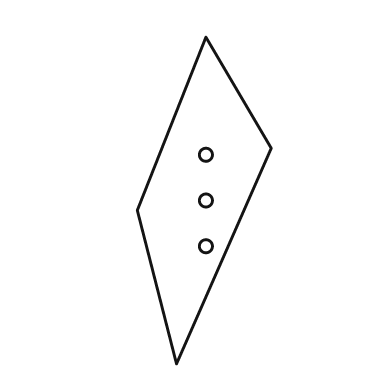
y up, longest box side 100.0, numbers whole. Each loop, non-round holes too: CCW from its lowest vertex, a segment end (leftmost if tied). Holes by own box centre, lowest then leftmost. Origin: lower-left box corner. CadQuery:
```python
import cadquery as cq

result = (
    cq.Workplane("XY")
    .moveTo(12.0, 0.0)
    .lineTo(41.0, 66.0)
    .lineTo(21.0, 100.0)
    .lineTo(0.0, 47.0)
    .close()
    .moveTo(21.0, 36.0)
    .circle(2.0)
    .moveTo(21.0, 50.0)
    .circle(2.0)
    .moveTo(21.0, 64.0)
    .circle(2.0)
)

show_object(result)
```